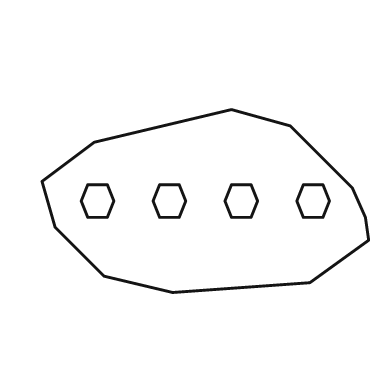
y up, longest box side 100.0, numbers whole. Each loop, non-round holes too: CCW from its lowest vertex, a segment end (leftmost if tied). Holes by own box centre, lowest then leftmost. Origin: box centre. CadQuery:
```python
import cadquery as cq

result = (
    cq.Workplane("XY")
    .moveTo(-10.0, -28.0)
    .lineTo(32.0, -25.0)
    .lineTo(50.0, -12.0)
    .lineTo(49.0, -5.0)
    .lineTo(45.0, 4.0)
    .lineTo(26.0, 23.0)
    .lineTo(8.0, 28.0)
    .lineTo(-34.0, 18.0)
    .lineTo(-50.0, 6.0)
    .lineTo(-46.0, -8.0)
    .lineTo(-31.0, -23.0)
    .close()
    .moveTo(-36.0, -5.0)
    .lineTo(-30.0, -5.0)
    .lineTo(-28.0, 0.0)
    .lineTo(-30.0, 5.0)
    .lineTo(-36.0, 5.0)
    .lineTo(-38.0, 0.0)
    .close()
    .moveTo(-14.0, -5.0)
    .lineTo(-8.0, -5.0)
    .lineTo(-6.0, 0.0)
    .lineTo(-8.0, 5.0)
    .lineTo(-14.0, 5.0)
    .lineTo(-16.0, 0.0)
    .close()
    .moveTo(8.0, -5.0)
    .lineTo(14.0, -5.0)
    .lineTo(16.0, 0.0)
    .lineTo(14.0, 5.0)
    .lineTo(8.0, 5.0)
    .lineTo(6.0, 0.0)
    .close()
    .moveTo(30.0, -5.0)
    .lineTo(36.0, -5.0)
    .lineTo(38.0, 0.0)
    .lineTo(36.0, 5.0)
    .lineTo(30.0, 5.0)
    .lineTo(28.0, 0.0)
    .close()
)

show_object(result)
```